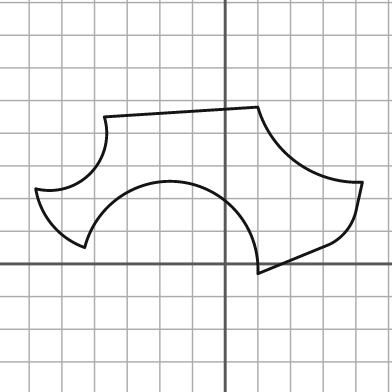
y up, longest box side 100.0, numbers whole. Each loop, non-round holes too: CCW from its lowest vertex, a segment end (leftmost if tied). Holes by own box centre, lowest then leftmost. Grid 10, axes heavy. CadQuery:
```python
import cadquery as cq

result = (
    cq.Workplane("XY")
    .moveTo(10.0, -3.0)
    .lineTo(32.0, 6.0)
    .threePointArc((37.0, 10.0), (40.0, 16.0))
    .lineTo(42.0, 25.0)
    .threePointArc((22.0, 31.0), (10.0, 48.0))
    .lineTo(-37.0, 45.0)
    .threePointArc((-41.0, 28.0), (-58.0, 23.0))
    .threePointArc((-53.0, 12.0), (-43.0, 5.0))
    .threePointArc((-13.0, 25.0), (10.0, -3.0))
    .close()
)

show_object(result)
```